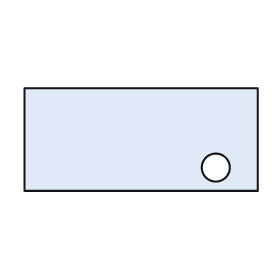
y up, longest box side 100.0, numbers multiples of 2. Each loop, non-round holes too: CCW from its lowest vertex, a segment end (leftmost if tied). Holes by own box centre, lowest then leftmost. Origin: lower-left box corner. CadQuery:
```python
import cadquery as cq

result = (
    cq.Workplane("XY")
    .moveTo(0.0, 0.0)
    .lineTo(100.0, 0.0)
    .lineTo(100.0, 44.0)
    .lineTo(0.0, 44.0)
    .close()
    .moveTo(82.0, 10.0)
    .circle(6.0)
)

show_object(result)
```